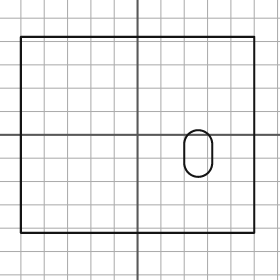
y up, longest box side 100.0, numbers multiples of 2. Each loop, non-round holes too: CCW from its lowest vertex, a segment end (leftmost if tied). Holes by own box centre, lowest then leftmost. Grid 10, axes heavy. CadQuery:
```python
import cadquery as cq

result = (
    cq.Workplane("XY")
    .moveTo(-50.0, -42.0)
    .lineTo(50.0, -42.0)
    .lineTo(50.0, 42.0)
    .lineTo(-50.0, 42.0)
    .close()
    .moveTo(20.0, -12.0)
    .threePointArc((26.0, -18.0), (32.0, -12.0))
    .lineTo(32.0, -4.0)
    .threePointArc((26.0, 2.0), (20.0, -4.0))
    .close()
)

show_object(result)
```